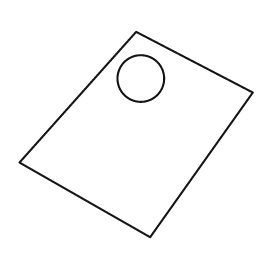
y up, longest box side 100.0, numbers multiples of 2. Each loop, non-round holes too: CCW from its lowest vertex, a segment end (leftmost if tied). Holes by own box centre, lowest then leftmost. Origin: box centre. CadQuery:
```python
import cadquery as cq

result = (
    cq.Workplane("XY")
    .moveTo(6.0, -44.0)
    .lineTo(50.0, 18.0)
    .lineTo(0.0, 44.0)
    .lineTo(-50.0, -12.0)
    .close()
    .moveTo(2.0, 24.0)
    .circle(10.0)
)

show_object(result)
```